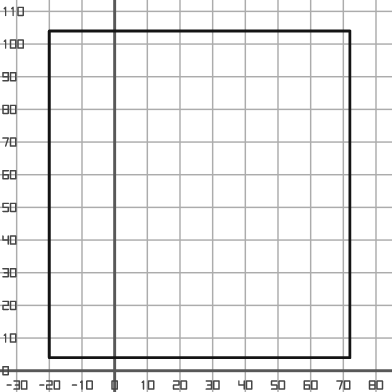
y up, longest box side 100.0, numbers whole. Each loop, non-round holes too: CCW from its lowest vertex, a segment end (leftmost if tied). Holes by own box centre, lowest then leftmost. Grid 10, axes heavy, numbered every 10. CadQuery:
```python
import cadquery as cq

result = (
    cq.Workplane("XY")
    .moveTo(-20.0, 4.0)
    .lineTo(72.0, 4.0)
    .lineTo(72.0, 104.0)
    .lineTo(-20.0, 104.0)
    .close()
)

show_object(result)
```